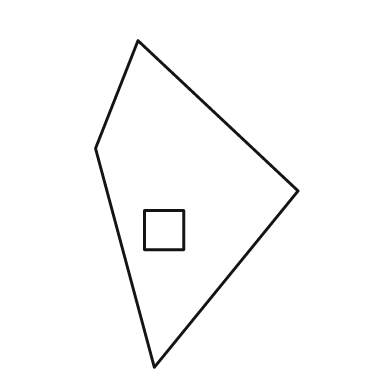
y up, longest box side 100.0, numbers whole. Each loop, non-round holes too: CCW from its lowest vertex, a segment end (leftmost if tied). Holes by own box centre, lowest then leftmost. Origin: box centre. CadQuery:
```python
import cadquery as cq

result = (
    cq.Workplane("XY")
    .moveTo(-13.0, -50.0)
    .lineTo(31.0, 4.0)
    .lineTo(-18.0, 50.0)
    .lineTo(-31.0, 17.0)
    .close()
    .moveTo(-16.0, -14.0)
    .lineTo(-4.0, -14.0)
    .lineTo(-4.0, -2.0)
    .lineTo(-16.0, -2.0)
    .close()
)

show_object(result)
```